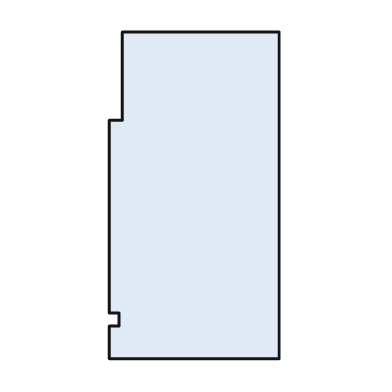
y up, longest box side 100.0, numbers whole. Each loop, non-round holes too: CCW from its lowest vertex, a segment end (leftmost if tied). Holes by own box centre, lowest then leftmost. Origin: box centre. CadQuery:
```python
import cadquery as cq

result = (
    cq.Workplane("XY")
    .moveTo(-26.0, -50.0)
    .lineTo(26.0, -50.0)
    .lineTo(26.0, 50.0)
    .lineTo(-22.0, 50.0)
    .lineTo(-22.0, 23.0)
    .lineTo(-26.0, 23.0)
    .lineTo(-26.0, -36.0)
    .lineTo(-23.0, -36.0)
    .lineTo(-23.0, -40.0)
    .lineTo(-26.0, -40.0)
    .close()
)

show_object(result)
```